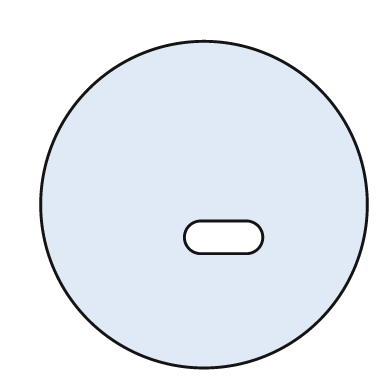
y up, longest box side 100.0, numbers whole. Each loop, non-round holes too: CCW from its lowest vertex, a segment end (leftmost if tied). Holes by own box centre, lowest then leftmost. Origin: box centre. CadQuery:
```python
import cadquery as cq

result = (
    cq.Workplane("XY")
    .moveTo(0.0, 0.0)
    .circle(50.0)
    .moveTo(-1.0, -15.0)
    .lineTo(13.0, -15.0)
    .threePointArc((18.0, -10.0), (13.0, -5.0))
    .lineTo(-1.0, -5.0)
    .threePointArc((-6.0, -10.0), (-1.0, -15.0))
    .close()
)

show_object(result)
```